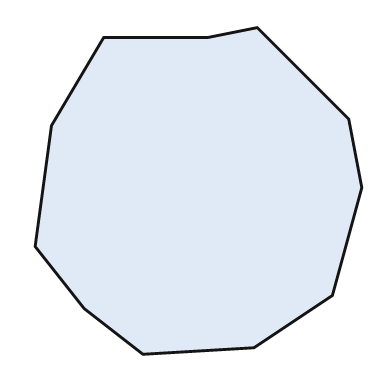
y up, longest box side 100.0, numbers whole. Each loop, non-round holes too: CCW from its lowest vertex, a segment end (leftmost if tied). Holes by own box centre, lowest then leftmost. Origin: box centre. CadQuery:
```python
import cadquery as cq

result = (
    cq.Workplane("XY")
    .moveTo(-17.0, -50.0)
    .lineTo(17.0, -48.0)
    .lineTo(41.0, -32.0)
    .lineTo(50.0, 1.0)
    .lineTo(46.0, 22.0)
    .lineTo(18.0, 50.0)
    .lineTo(3.0, 47.0)
    .lineTo(-29.0, 47.0)
    .lineTo(-45.0, 20.0)
    .lineTo(-50.0, -17.0)
    .lineTo(-35.0, -36.0)
    .close()
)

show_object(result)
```